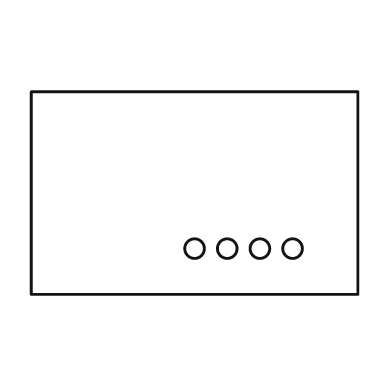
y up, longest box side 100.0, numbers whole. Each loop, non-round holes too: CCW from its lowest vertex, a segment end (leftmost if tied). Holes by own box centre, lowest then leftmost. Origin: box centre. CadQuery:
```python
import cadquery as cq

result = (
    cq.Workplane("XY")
    .moveTo(-50.0, -31.0)
    .lineTo(50.0, -31.0)
    .lineTo(50.0, 31.0)
    .lineTo(-50.0, 31.0)
    .close()
    .moveTo(0.0, -17.0)
    .circle(3.0)
    .moveTo(10.0, -17.0)
    .circle(3.0)
    .moveTo(20.0, -17.0)
    .circle(3.0)
    .moveTo(30.0, -17.0)
    .circle(3.0)
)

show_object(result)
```